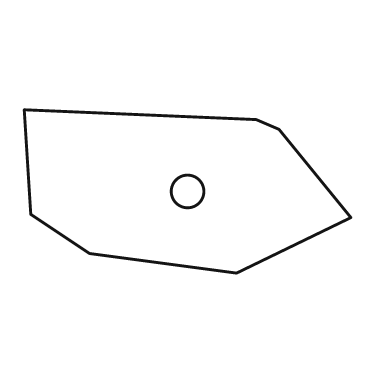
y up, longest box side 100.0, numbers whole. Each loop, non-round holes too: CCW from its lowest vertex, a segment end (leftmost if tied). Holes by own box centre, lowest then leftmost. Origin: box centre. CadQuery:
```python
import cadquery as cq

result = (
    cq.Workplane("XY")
    .moveTo(15.0, -25.0)
    .lineTo(50.0, -8.0)
    .lineTo(28.0, 19.0)
    .lineTo(21.0, 22.0)
    .lineTo(-50.0, 25.0)
    .lineTo(-48.0, -7.0)
    .lineTo(-30.0, -19.0)
    .close()
    .moveTo(0.0, 0.0)
    .circle(5.0)
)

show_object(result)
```